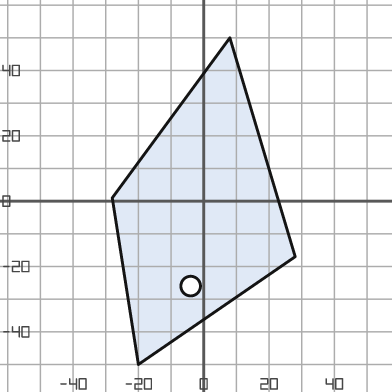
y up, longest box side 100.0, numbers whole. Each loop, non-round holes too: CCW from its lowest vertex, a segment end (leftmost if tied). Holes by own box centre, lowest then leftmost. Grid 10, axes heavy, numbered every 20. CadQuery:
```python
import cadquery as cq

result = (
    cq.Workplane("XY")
    .moveTo(-20.0, -50.0)
    .lineTo(28.0, -17.0)
    .lineTo(8.0, 50.0)
    .lineTo(-28.0, 1.0)
    .close()
    .moveTo(-4.0, -26.0)
    .circle(3.0)
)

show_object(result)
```